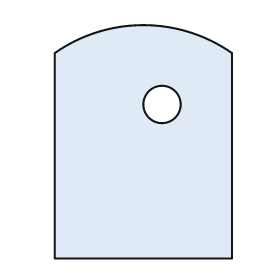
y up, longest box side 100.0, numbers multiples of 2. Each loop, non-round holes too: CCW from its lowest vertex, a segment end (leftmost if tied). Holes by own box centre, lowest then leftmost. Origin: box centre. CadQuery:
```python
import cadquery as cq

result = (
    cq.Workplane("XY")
    .moveTo(-38.0, -50.0)
    .lineTo(38.0, -50.0)
    .lineTo(38.0, 38.0)
    .threePointArc((0.0, 50.0), (-38.0, 38.0))
    .close()
    .moveTo(8.0, 16.0)
    .circle(8.0)
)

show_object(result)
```